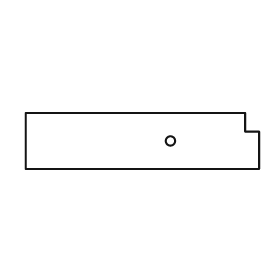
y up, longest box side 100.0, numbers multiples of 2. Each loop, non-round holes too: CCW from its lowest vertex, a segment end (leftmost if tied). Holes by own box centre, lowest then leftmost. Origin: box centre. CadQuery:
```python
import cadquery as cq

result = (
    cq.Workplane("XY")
    .moveTo(-50.0, -12.0)
    .lineTo(50.0, -12.0)
    .lineTo(50.0, 4.0)
    .lineTo(44.0, 4.0)
    .lineTo(44.0, 12.0)
    .lineTo(-50.0, 12.0)
    .close()
    .moveTo(12.0, 0.0)
    .circle(2.0)
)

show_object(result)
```